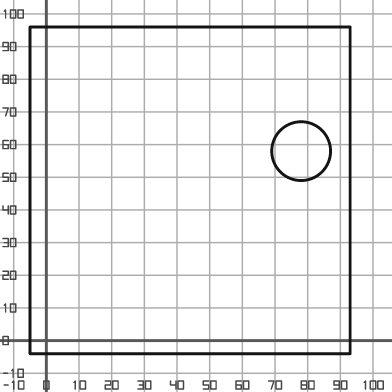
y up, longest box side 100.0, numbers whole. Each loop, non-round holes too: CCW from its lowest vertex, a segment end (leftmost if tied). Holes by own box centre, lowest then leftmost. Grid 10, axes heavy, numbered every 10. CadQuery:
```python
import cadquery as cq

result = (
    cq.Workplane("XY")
    .moveTo(-5.0, -4.0)
    .lineTo(93.0, -4.0)
    .lineTo(93.0, 96.0)
    .lineTo(-5.0, 96.0)
    .close()
    .moveTo(78.0, 58.0)
    .circle(9.0)
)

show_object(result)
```